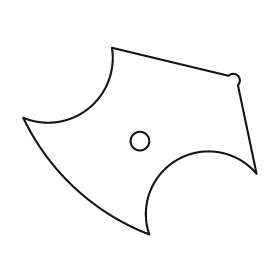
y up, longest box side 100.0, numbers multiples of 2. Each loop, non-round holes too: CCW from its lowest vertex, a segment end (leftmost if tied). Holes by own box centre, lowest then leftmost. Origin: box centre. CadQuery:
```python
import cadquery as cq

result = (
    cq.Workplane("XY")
    .moveTo(4.0, -40.0)
    .threePointArc((16.0, -8.0), (50.0, -14.0))
    .lineTo(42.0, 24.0)
    .threePointArc((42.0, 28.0), (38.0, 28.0))
    .lineTo(-12.0, 40.0)
    .threePointArc((-22.0, 14.0), (-50.0, 10.0))
    .threePointArc((-28.0, -20.0), (4.0, -40.0))
    .close()
    .moveTo(0.0, 0.0)
    .circle(4.0)
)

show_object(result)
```